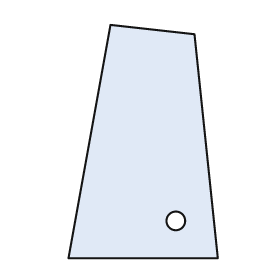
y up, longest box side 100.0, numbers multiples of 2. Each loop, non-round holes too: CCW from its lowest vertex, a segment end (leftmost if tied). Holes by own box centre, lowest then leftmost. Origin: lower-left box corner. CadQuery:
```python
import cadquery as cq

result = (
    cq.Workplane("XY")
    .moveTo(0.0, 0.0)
    .lineTo(64.0, 0.0)
    .lineTo(54.0, 96.0)
    .lineTo(18.0, 100.0)
    .close()
    .moveTo(46.0, 16.0)
    .circle(4.0)
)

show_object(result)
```